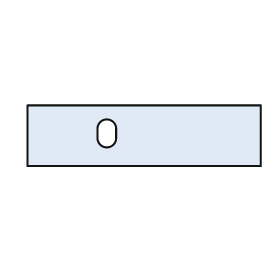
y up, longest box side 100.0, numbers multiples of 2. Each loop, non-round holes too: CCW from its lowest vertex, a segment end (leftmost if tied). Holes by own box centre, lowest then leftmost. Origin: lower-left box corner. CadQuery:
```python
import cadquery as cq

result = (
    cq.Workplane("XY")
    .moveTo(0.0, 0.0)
    .lineTo(100.0, 0.0)
    .lineTo(100.0, 26.0)
    .lineTo(0.0, 26.0)
    .close()
    .moveTo(30.0, 12.0)
    .threePointArc((34.0, 8.0), (38.0, 12.0))
    .lineTo(38.0, 16.0)
    .threePointArc((34.0, 20.0), (30.0, 16.0))
    .close()
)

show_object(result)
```